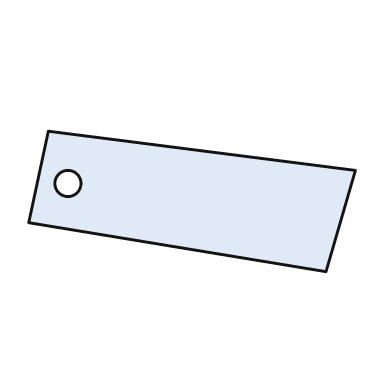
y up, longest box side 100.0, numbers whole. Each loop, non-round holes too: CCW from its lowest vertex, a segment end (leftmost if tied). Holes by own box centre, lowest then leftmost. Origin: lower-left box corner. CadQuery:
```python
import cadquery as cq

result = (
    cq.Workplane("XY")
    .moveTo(91.0, 0.0)
    .lineTo(100.0, 31.0)
    .lineTo(6.0, 43.0)
    .lineTo(0.0, 15.0)
    .close()
    .moveTo(12.0, 27.0)
    .circle(4.0)
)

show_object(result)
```